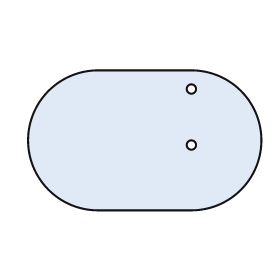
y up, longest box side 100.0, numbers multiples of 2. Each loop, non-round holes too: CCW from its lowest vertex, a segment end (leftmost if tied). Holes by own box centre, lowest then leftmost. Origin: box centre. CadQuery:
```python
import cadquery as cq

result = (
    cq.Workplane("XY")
    .moveTo(-20.0, -30.0)
    .lineTo(20.0, -30.0)
    .threePointArc((50.0, 0.0), (20.0, 30.0))
    .lineTo(-20.0, 30.0)
    .threePointArc((-50.0, 0.0), (-20.0, -30.0))
    .close()
    .moveTo(20.0, -2.0)
    .circle(2.0)
    .moveTo(20.0, 22.0)
    .circle(2.0)
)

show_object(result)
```